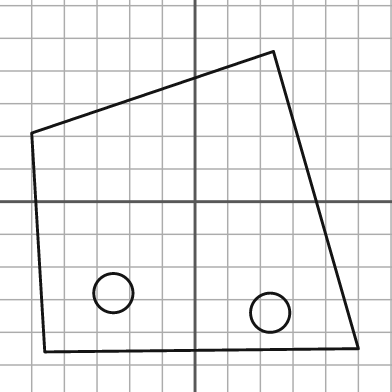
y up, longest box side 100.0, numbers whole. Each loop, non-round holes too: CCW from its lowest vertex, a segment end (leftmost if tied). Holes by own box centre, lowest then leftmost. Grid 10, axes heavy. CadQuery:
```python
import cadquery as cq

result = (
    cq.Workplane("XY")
    .moveTo(-46.0, -46.0)
    .lineTo(50.0, -45.0)
    .lineTo(24.0, 46.0)
    .lineTo(-50.0, 21.0)
    .close()
    .moveTo(23.0, -34.0)
    .circle(6.0)
    .moveTo(-25.0, -28.0)
    .circle(6.0)
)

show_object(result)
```